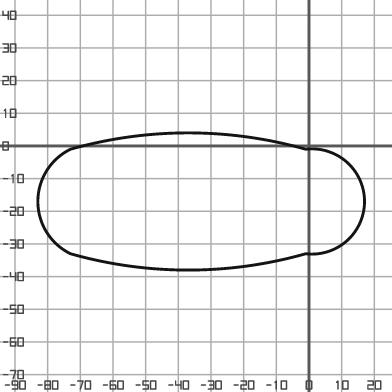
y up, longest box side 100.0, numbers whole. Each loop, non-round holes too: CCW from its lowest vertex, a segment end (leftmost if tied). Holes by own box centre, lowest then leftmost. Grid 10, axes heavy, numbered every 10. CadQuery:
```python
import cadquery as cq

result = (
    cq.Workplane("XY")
    .moveTo(-73.0, -33.0)
    .threePointArc((-37.0, -38.0), (-1.0, -33.0))
    .threePointArc((17.0, -17.0), (-1.0, -1.0))
    .threePointArc((-37.0, 4.0), (-73.0, -1.0))
    .threePointArc((-83.0, -17.0), (-73.0, -33.0))
    .close()
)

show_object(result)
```